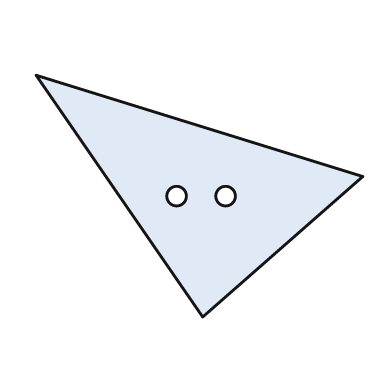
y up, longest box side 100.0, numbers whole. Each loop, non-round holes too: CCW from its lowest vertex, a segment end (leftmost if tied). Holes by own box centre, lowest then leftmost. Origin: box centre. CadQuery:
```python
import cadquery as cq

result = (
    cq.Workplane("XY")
    .moveTo(1.0, -37.0)
    .lineTo(50.0, 6.0)
    .lineTo(-50.0, 37.0)
    .close()
    .moveTo(-7.0, 0.0)
    .circle(3.0)
    .moveTo(8.0, 0.0)
    .circle(3.0)
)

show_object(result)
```